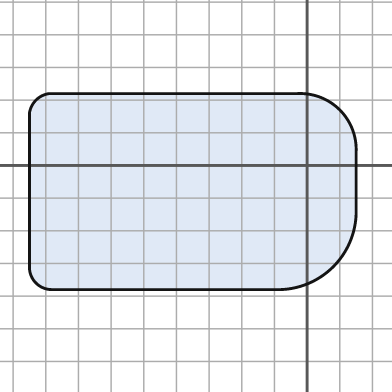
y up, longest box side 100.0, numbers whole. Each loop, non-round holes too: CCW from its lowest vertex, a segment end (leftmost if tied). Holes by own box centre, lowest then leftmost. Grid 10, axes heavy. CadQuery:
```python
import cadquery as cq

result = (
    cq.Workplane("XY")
    .moveTo(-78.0, -38.0)
    .lineTo(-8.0, -38.0)
    .threePointArc((8.0, -31.0), (15.0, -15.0))
    .lineTo(15.0, 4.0)
    .threePointArc((10.0, 17.0), (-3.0, 22.0))
    .lineTo(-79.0, 22.0)
    .threePointArc((-83.0, 20.0), (-85.0, 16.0))
    .lineTo(-85.0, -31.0)
    .threePointArc((-83.0, -36.0), (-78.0, -38.0))
    .close()
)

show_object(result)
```